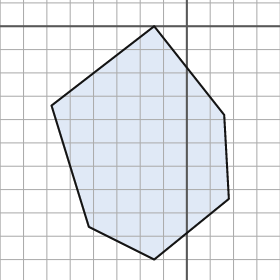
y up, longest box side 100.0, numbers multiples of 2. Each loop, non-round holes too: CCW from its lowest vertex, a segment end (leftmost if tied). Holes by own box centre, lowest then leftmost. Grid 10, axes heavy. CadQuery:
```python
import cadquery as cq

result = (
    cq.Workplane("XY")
    .moveTo(-14.0, -100.0)
    .lineTo(18.0, -74.0)
    .lineTo(16.0, -38.0)
    .lineTo(-14.0, 0.0)
    .lineTo(-58.0, -34.0)
    .lineTo(-42.0, -86.0)
    .close()
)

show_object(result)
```